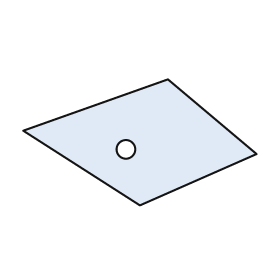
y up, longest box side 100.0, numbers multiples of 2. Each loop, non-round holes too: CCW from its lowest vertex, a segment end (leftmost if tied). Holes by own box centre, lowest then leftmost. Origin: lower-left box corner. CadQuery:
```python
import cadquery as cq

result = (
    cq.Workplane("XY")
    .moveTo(50.0, 0.0)
    .lineTo(100.0, 22.0)
    .lineTo(62.0, 54.0)
    .lineTo(0.0, 32.0)
    .close()
    .moveTo(44.0, 24.0)
    .circle(4.0)
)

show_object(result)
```